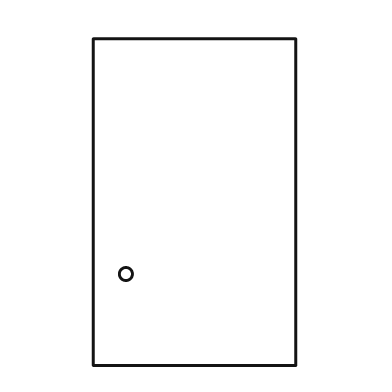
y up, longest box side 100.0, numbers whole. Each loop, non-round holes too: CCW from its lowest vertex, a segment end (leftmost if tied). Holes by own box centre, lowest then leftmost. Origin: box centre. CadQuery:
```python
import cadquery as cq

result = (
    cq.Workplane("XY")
    .moveTo(-31.0, -50.0)
    .lineTo(31.0, -50.0)
    .lineTo(31.0, 50.0)
    .lineTo(-31.0, 50.0)
    .close()
    .moveTo(-21.0, -22.0)
    .circle(2.0)
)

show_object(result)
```